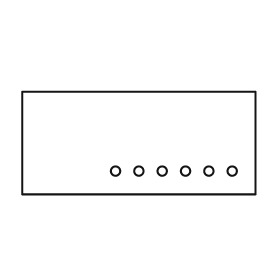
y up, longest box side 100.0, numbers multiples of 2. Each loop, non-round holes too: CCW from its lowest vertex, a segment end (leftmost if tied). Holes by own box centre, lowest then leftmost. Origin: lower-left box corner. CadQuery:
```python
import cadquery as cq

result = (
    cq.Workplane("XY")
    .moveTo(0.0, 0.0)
    .lineTo(100.0, 0.0)
    .lineTo(100.0, 44.0)
    .lineTo(0.0, 44.0)
    .close()
    .moveTo(40.0, 10.0)
    .circle(2.0)
    .moveTo(50.0, 10.0)
    .circle(2.0)
    .moveTo(60.0, 10.0)
    .circle(2.0)
    .moveTo(70.0, 10.0)
    .circle(2.0)
    .moveTo(80.0, 10.0)
    .circle(2.0)
    .moveTo(90.0, 10.0)
    .circle(2.0)
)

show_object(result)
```